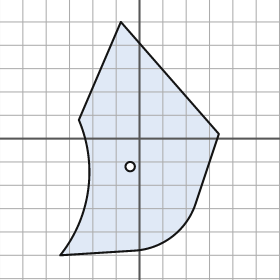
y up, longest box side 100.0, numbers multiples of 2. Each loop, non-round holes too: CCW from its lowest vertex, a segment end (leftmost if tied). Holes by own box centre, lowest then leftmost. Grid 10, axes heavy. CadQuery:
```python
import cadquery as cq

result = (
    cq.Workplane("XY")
    .moveTo(-34.0, -50.0)
    .lineTo(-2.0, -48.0)
    .threePointArc((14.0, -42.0), (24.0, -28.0))
    .lineTo(34.0, 2.0)
    .lineTo(-8.0, 50.0)
    .lineTo(-26.0, 8.0)
    .threePointArc((-22.0, -22.0), (-34.0, -50.0))
    .close()
    .moveTo(-4.0, -12.0)
    .circle(2.0)
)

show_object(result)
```